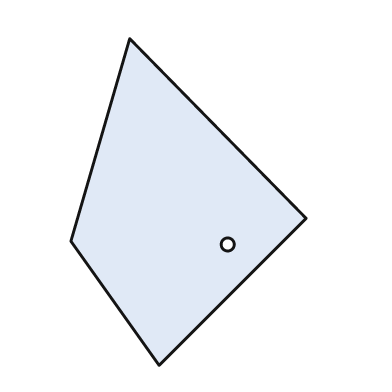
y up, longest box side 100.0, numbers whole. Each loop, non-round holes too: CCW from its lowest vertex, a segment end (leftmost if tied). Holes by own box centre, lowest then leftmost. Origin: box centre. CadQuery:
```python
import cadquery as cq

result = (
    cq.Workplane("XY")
    .moveTo(-9.0, -50.0)
    .lineTo(36.0, -5.0)
    .lineTo(-18.0, 50.0)
    .lineTo(-36.0, -12.0)
    .close()
    .moveTo(12.0, -13.0)
    .circle(2.0)
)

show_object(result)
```